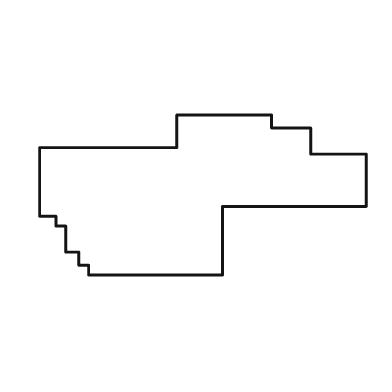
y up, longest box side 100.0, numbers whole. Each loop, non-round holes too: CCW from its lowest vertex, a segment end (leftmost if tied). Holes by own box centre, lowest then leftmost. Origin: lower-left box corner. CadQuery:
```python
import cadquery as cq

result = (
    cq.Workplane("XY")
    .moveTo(15.0, 0.0)
    .lineTo(56.0, 0.0)
    .lineTo(56.0, 21.0)
    .lineTo(100.0, 21.0)
    .lineTo(100.0, 37.0)
    .lineTo(83.0, 37.0)
    .lineTo(83.0, 45.0)
    .lineTo(71.0, 45.0)
    .lineTo(71.0, 49.0)
    .lineTo(42.0, 49.0)
    .lineTo(42.0, 39.0)
    .lineTo(0.0, 39.0)
    .lineTo(0.0, 18.0)
    .lineTo(5.0, 18.0)
    .lineTo(5.0, 15.0)
    .lineTo(8.0, 15.0)
    .lineTo(8.0, 7.0)
    .lineTo(12.0, 7.0)
    .lineTo(12.0, 3.0)
    .lineTo(15.0, 3.0)
    .close()
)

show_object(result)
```